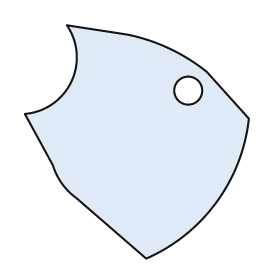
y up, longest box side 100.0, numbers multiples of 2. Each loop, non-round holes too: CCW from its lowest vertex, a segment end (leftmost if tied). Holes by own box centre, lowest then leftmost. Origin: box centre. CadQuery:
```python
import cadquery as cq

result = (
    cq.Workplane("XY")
    .moveTo(4.0, -50.0)
    .threePointArc((34.0, -26.0), (48.0, 10.0))
    .lineTo(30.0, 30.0)
    .threePointArc((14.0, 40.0), (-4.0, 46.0))
    .lineTo(-30.0, 50.0)
    .threePointArc((-28.0, 26.0), (-48.0, 12.0))
    .lineTo(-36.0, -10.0)
    .threePointArc((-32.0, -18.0), (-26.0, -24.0))
    .close()
    .moveTo(22.0, 22.0)
    .circle(6.0)
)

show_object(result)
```